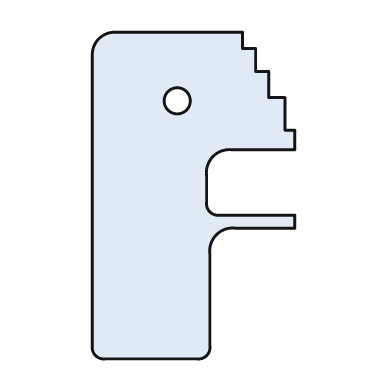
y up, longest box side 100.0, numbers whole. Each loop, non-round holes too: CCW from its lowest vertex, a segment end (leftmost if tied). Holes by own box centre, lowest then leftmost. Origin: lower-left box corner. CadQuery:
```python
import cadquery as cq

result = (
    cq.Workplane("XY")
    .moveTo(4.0, 0.0)
    .lineTo(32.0, 0.0)
    .threePointArc((35.0, 1.0), (36.0, 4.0))
    .lineTo(36.0, 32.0)
    .threePointArc((38.0, 38.0), (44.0, 40.0))
    .lineTo(62.0, 40.0)
    .lineTo(62.0, 44.0)
    .lineTo(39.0, 44.0)
    .threePointArc((36.0, 45.0), (35.0, 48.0))
    .lineTo(35.0, 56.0)
    .threePointArc((37.0, 62.0), (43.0, 64.0))
    .lineTo(62.0, 64.0)
    .lineTo(62.0, 70.0)
    .lineTo(59.0, 70.0)
    .lineTo(59.0, 80.0)
    .lineTo(54.0, 80.0)
    .lineTo(54.0, 88.0)
    .lineTo(50.0, 88.0)
    .lineTo(50.0, 95.0)
    .lineTo(46.0, 95.0)
    .lineTo(46.0, 100.0)
    .lineTo(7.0, 100.0)
    .threePointArc((2.0, 98.0), (0.0, 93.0))
    .lineTo(0.0, 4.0)
    .threePointArc((1.0, 1.0), (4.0, 0.0))
    .close()
    .moveTo(26.0, 79.0)
    .circle(4.0)
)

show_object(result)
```